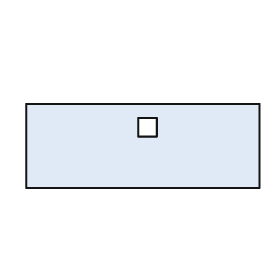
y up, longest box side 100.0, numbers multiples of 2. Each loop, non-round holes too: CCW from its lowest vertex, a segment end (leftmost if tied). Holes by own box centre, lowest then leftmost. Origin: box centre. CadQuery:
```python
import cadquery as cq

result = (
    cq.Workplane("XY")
    .moveTo(-50.0, -18.0)
    .lineTo(50.0, -18.0)
    .lineTo(50.0, 18.0)
    .lineTo(-50.0, 18.0)
    .close()
    .moveTo(-2.0, 4.0)
    .lineTo(6.0, 4.0)
    .lineTo(6.0, 12.0)
    .lineTo(-2.0, 12.0)
    .close()
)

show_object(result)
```